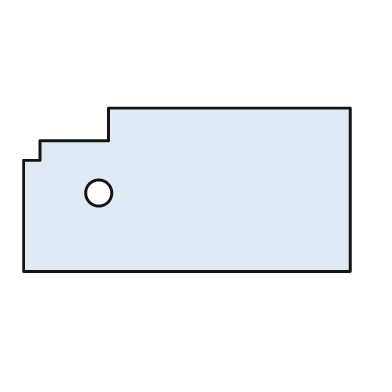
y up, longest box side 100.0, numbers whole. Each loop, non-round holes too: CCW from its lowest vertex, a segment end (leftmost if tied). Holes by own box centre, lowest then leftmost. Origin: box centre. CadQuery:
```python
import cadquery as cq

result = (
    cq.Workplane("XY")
    .moveTo(-50.0, -25.0)
    .lineTo(50.0, -25.0)
    .lineTo(50.0, 25.0)
    .lineTo(-24.0, 25.0)
    .lineTo(-24.0, 15.0)
    .lineTo(-45.0, 15.0)
    .lineTo(-45.0, 9.0)
    .lineTo(-50.0, 9.0)
    .close()
    .moveTo(-27.0, -1.0)
    .circle(4.0)
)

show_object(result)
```